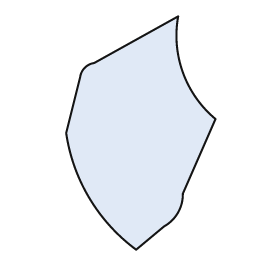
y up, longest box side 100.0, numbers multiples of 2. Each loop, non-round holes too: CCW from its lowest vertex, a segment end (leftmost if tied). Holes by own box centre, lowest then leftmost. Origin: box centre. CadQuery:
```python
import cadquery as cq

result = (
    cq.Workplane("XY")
    .moveTo(-2.0, -50.0)
    .lineTo(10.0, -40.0)
    .threePointArc((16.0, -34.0), (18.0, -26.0))
    .lineTo(32.0, 6.0)
    .threePointArc((18.0, 26.0), (16.0, 50.0))
    .lineTo(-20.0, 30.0)
    .threePointArc((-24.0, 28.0), (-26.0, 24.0))
    .lineTo(-32.0, 0.0)
    .threePointArc((-22.0, -28.0), (-2.0, -50.0))
    .close()
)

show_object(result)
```